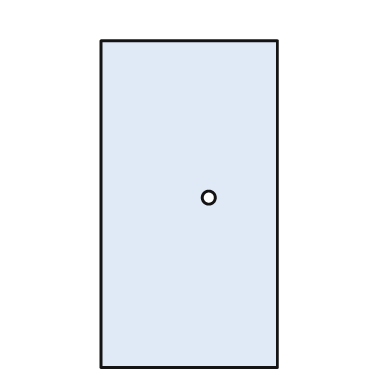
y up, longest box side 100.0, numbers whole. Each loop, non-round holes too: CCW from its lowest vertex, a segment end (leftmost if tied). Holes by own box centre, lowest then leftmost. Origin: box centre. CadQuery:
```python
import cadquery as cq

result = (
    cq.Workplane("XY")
    .moveTo(-27.0, -50.0)
    .lineTo(27.0, -50.0)
    .lineTo(27.0, 50.0)
    .lineTo(-27.0, 50.0)
    .close()
    .moveTo(6.0, 2.0)
    .circle(2.0)
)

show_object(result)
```